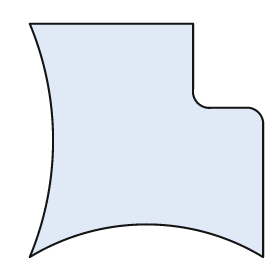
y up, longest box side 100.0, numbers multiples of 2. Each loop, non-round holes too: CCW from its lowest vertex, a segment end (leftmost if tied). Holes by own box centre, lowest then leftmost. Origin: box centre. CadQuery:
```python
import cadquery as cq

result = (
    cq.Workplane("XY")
    .moveTo(-50.0, -50.0)
    .threePointArc((0.0, -36.0), (50.0, -50.0))
    .lineTo(50.0, 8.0)
    .threePointArc((48.0, 12.0), (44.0, 14.0))
    .lineTo(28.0, 14.0)
    .threePointArc((22.0, 16.0), (20.0, 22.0))
    .lineTo(20.0, 50.0)
    .lineTo(-50.0, 50.0)
    .threePointArc((-40.0, 0.0), (-50.0, -50.0))
    .close()
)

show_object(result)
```